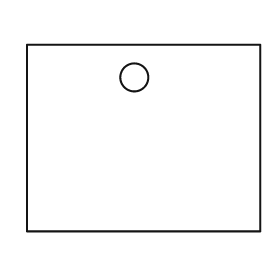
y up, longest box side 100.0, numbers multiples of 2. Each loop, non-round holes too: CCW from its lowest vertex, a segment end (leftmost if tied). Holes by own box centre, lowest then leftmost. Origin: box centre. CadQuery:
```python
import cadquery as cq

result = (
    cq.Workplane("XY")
    .moveTo(-50.0, -40.0)
    .lineTo(50.0, -40.0)
    .lineTo(50.0, 40.0)
    .lineTo(-50.0, 40.0)
    .close()
    .moveTo(-4.0, 26.0)
    .circle(6.0)
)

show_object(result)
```